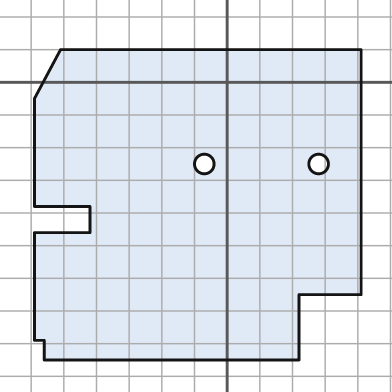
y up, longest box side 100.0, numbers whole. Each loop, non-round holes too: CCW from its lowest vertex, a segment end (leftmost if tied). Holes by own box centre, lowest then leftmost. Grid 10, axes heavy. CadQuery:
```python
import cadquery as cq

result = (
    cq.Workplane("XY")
    .moveTo(-56.0, -85.0)
    .lineTo(22.0, -85.0)
    .lineTo(22.0, -65.0)
    .lineTo(41.0, -65.0)
    .lineTo(41.0, 10.0)
    .lineTo(-51.0, 10.0)
    .lineTo(-59.0, -5.0)
    .lineTo(-59.0, -38.0)
    .lineTo(-42.0, -38.0)
    .lineTo(-42.0, -46.0)
    .lineTo(-59.0, -46.0)
    .lineTo(-59.0, -79.0)
    .lineTo(-56.0, -79.0)
    .close()
    .moveTo(-7.0, -25.0)
    .circle(3.0)
    .moveTo(28.0, -25.0)
    .circle(3.0)
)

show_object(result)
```